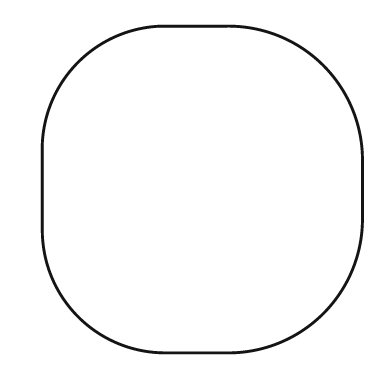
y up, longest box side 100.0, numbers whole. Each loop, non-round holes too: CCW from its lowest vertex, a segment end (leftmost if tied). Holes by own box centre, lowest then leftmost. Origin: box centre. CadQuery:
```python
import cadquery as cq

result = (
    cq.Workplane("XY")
    .moveTo(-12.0, -50.0)
    .lineTo(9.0, -50.0)
    .threePointArc((37.0, -38.0), (49.0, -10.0))
    .lineTo(49.0, 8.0)
    .threePointArc((37.0, 38.0), (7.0, 50.0))
    .lineTo(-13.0, 50.0)
    .threePointArc((-38.0, 39.0), (-49.0, 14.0))
    .lineTo(-49.0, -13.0)
    .threePointArc((-38.0, -39.0), (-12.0, -50.0))
    .close()
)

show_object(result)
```